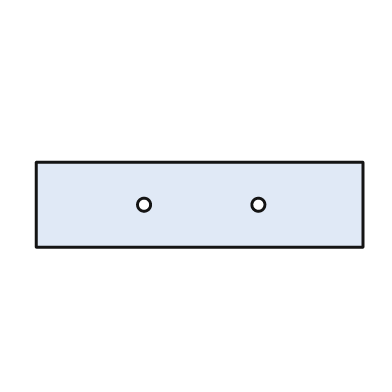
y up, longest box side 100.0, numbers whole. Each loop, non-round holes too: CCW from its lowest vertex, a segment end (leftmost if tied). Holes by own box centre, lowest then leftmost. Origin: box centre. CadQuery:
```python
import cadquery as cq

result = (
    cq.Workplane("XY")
    .moveTo(-50.0, -13.0)
    .lineTo(50.0, -13.0)
    .lineTo(50.0, 13.0)
    .lineTo(-50.0, 13.0)
    .close()
    .moveTo(-17.0, 0.0)
    .circle(2.0)
    .moveTo(18.0, 0.0)
    .circle(2.0)
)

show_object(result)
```